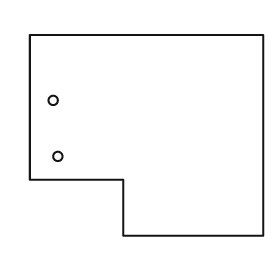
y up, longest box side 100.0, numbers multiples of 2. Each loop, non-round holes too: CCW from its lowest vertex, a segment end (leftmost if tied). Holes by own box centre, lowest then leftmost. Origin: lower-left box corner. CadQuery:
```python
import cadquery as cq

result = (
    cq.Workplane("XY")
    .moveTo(40.0, 0.0)
    .lineTo(100.0, 0.0)
    .lineTo(100.0, 86.0)
    .lineTo(0.0, 86.0)
    .lineTo(0.0, 24.0)
    .lineTo(40.0, 24.0)
    .close()
    .moveTo(12.0, 34.0)
    .circle(2.0)
    .moveTo(10.0, 58.0)
    .circle(2.0)
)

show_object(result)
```